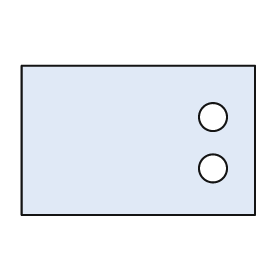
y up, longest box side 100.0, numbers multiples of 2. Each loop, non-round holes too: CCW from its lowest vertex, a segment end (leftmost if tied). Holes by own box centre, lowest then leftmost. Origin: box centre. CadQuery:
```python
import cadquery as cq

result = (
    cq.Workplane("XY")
    .moveTo(-50.0, -32.0)
    .lineTo(50.0, -32.0)
    .lineTo(50.0, 32.0)
    .lineTo(-50.0, 32.0)
    .close()
    .moveTo(32.0, -12.0)
    .circle(6.0)
    .moveTo(32.0, 10.0)
    .circle(6.0)
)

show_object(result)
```